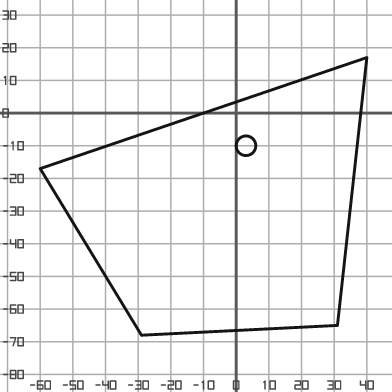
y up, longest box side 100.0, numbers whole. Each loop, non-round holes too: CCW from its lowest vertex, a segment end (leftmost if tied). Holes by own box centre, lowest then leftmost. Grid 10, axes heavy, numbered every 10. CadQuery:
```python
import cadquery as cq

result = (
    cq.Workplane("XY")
    .moveTo(-29.0, -68.0)
    .lineTo(31.0, -65.0)
    .lineTo(40.0, 17.0)
    .lineTo(-60.0, -17.0)
    .close()
    .moveTo(3.0, -10.0)
    .circle(3.0)
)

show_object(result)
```